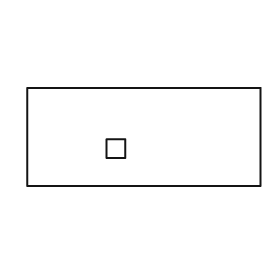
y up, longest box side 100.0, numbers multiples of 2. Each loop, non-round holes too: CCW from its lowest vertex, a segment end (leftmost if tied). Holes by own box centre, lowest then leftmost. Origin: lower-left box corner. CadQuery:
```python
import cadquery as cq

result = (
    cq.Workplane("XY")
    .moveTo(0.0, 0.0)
    .lineTo(100.0, 0.0)
    .lineTo(100.0, 42.0)
    .lineTo(0.0, 42.0)
    .close()
    .moveTo(34.0, 12.0)
    .lineTo(42.0, 12.0)
    .lineTo(42.0, 20.0)
    .lineTo(34.0, 20.0)
    .close()
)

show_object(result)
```